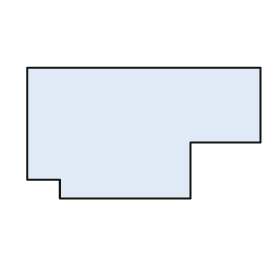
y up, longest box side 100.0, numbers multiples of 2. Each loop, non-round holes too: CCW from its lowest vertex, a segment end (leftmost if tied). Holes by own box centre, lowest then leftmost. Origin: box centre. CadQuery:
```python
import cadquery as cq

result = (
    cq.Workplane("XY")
    .moveTo(-36.0, -28.0)
    .lineTo(20.0, -28.0)
    .lineTo(20.0, -4.0)
    .lineTo(50.0, -4.0)
    .lineTo(50.0, 28.0)
    .lineTo(-50.0, 28.0)
    .lineTo(-50.0, -20.0)
    .lineTo(-36.0, -20.0)
    .close()
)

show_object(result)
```